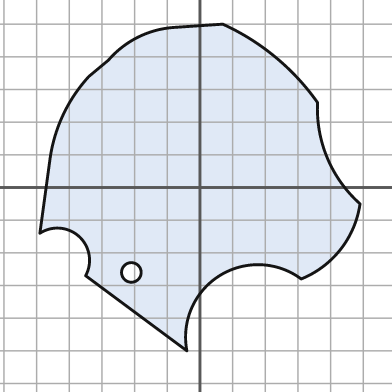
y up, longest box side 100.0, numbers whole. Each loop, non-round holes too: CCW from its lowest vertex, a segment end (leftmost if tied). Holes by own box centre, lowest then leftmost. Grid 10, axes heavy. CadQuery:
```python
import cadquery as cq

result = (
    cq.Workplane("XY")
    .moveTo(-4.0, -50.0)
    .threePointArc((6.0, -27.0), (31.0, -28.0))
    .threePointArc((43.0, -19.0), (49.0, -5.0))
    .threePointArc((39.0, 9.0), (36.0, 26.0))
    .threePointArc((23.0, 40.0), (7.0, 50.0))
    .lineTo(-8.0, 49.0)
    .threePointArc((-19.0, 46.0), (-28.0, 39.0))
    .lineTo(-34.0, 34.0)
    .threePointArc((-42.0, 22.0), (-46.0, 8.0))
    .lineTo(-49.0, -14.0)
    .threePointArc((-37.0, -15.0), (-35.0, -27.0))
    .close()
    .moveTo(-21.0, -26.0)
    .circle(3.0)
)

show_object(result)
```